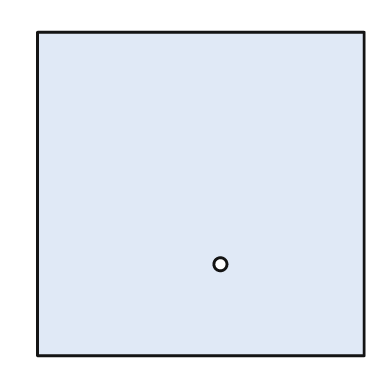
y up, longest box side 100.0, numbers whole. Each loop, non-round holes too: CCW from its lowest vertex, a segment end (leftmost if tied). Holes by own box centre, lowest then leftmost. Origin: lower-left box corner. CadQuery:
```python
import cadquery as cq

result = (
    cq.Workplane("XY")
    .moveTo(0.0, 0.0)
    .lineTo(100.0, 0.0)
    .lineTo(100.0, 99.0)
    .lineTo(0.0, 99.0)
    .close()
    .moveTo(56.0, 28.0)
    .circle(2.0)
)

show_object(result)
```